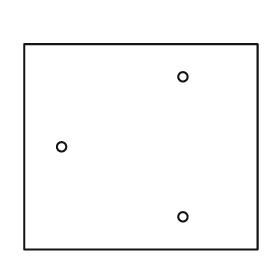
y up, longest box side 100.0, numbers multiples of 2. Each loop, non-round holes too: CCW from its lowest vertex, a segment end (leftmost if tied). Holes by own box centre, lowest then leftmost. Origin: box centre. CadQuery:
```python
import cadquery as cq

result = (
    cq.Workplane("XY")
    .moveTo(-50.0, -44.0)
    .lineTo(50.0, -44.0)
    .lineTo(50.0, 44.0)
    .lineTo(-50.0, 44.0)
    .close()
    .moveTo(18.0, -30.0)
    .circle(2.0)
    .moveTo(-34.0, 0.0)
    .circle(2.0)
    .moveTo(18.0, 30.0)
    .circle(2.0)
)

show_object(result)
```